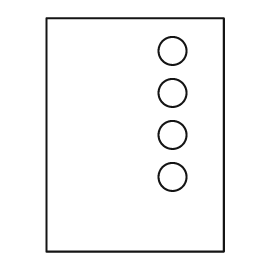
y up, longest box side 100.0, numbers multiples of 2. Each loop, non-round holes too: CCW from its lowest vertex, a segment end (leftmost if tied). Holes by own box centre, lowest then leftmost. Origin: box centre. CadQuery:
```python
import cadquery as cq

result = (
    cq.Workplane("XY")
    .moveTo(-38.0, -50.0)
    .lineTo(38.0, -50.0)
    .lineTo(38.0, 50.0)
    .lineTo(-38.0, 50.0)
    .close()
    .moveTo(16.0, -18.0)
    .circle(6.0)
    .moveTo(16.0, 0.0)
    .circle(6.0)
    .moveTo(16.0, 18.0)
    .circle(6.0)
    .moveTo(16.0, 36.0)
    .circle(6.0)
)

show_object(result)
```